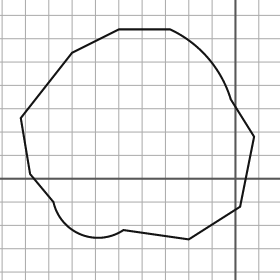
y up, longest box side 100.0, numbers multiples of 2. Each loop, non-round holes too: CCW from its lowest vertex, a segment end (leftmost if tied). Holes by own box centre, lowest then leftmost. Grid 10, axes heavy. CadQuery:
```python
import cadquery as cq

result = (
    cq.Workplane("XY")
    .moveTo(-20.0, -26.0)
    .lineTo(2.0, -12.0)
    .lineTo(8.0, 18.0)
    .lineTo(-2.0, 34.0)
    .threePointArc((-12.0, 52.0), (-28.0, 64.0))
    .lineTo(-50.0, 64.0)
    .lineTo(-70.0, 54.0)
    .lineTo(-92.0, 26.0)
    .lineTo(-88.0, 2.0)
    .lineTo(-78.0, -10.0)
    .threePointArc((-66.0, -24.0), (-48.0, -22.0))
    .close()
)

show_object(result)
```